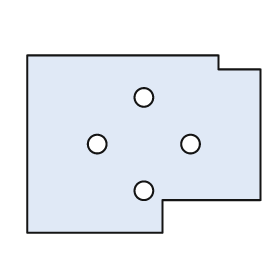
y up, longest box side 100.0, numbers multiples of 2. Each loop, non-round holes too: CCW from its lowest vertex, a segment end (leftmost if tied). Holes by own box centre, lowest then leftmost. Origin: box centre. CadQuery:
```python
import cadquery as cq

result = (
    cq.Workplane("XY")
    .moveTo(-50.0, -38.0)
    .lineTo(8.0, -38.0)
    .lineTo(8.0, -24.0)
    .lineTo(50.0, -24.0)
    .lineTo(50.0, 32.0)
    .lineTo(32.0, 32.0)
    .lineTo(32.0, 38.0)
    .lineTo(-50.0, 38.0)
    .close()
    .moveTo(0.0, -20.0)
    .circle(4.0)
    .moveTo(-20.0, 0.0)
    .circle(4.0)
    .moveTo(20.0, 0.0)
    .circle(4.0)
    .moveTo(0.0, 20.0)
    .circle(4.0)
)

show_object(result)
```